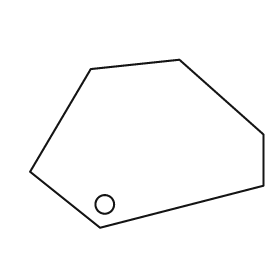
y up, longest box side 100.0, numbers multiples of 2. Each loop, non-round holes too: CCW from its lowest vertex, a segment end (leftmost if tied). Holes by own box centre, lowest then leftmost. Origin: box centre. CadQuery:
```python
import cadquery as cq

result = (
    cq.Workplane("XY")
    .moveTo(-20.0, -36.0)
    .lineTo(50.0, -18.0)
    .lineTo(50.0, 4.0)
    .lineTo(14.0, 36.0)
    .lineTo(-24.0, 32.0)
    .lineTo(-50.0, -12.0)
    .close()
    .moveTo(-18.0, -26.0)
    .circle(4.0)
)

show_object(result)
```